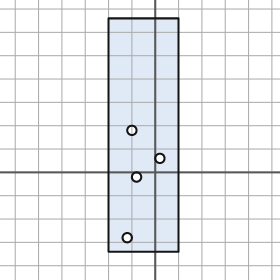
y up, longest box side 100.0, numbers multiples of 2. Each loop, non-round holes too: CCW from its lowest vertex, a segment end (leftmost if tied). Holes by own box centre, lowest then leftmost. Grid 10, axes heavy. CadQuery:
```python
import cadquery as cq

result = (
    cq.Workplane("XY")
    .moveTo(-20.0, -34.0)
    .lineTo(10.0, -34.0)
    .lineTo(10.0, 66.0)
    .lineTo(-20.0, 66.0)
    .close()
    .moveTo(-12.0, -28.0)
    .circle(2.0)
    .moveTo(-8.0, -2.0)
    .circle(2.0)
    .moveTo(2.0, 6.0)
    .circle(2.0)
    .moveTo(-10.0, 18.0)
    .circle(2.0)
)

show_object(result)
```